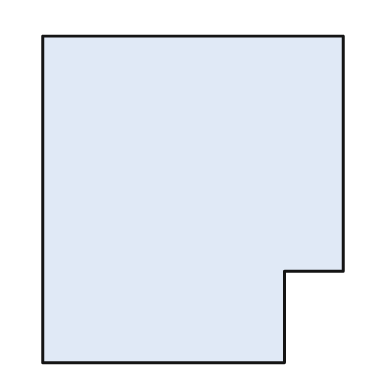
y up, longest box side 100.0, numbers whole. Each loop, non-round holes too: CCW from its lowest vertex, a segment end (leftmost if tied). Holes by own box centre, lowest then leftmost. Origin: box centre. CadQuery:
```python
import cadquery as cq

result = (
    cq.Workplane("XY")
    .moveTo(-46.0, -50.0)
    .lineTo(28.0, -50.0)
    .lineTo(28.0, -22.0)
    .lineTo(46.0, -22.0)
    .lineTo(46.0, 50.0)
    .lineTo(-46.0, 50.0)
    .close()
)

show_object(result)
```